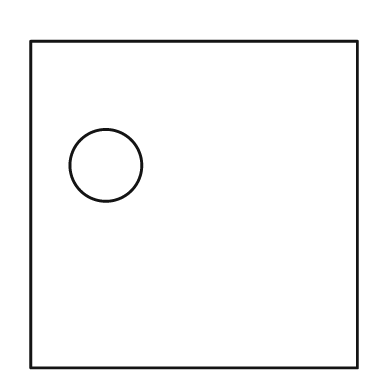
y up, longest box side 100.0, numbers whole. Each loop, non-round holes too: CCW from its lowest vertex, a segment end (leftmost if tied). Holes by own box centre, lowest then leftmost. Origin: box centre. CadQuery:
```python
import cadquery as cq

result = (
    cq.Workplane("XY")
    .moveTo(-50.0, -50.0)
    .lineTo(50.0, -50.0)
    .lineTo(50.0, 50.0)
    .lineTo(-50.0, 50.0)
    .close()
    .moveTo(-27.0, 12.0)
    .circle(11.0)
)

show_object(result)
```